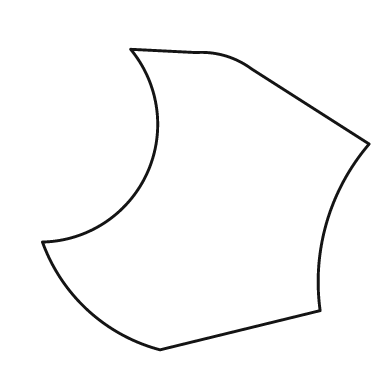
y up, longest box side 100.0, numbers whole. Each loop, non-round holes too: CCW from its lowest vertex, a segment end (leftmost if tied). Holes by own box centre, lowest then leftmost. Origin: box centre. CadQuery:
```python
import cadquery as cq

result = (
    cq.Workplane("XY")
    .moveTo(-14.0, -46.0)
    .lineTo(35.0, -34.0)
    .threePointArc((37.0, -7.0), (50.0, 17.0))
    .lineTo(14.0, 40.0)
    .threePointArc((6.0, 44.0), (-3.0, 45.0))
    .lineTo(-23.0, 46.0)
    .threePointArc((-18.0, 8.0), (-50.0, -13.0))
    .threePointArc((-36.0, -34.0), (-14.0, -46.0))
    .close()
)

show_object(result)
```